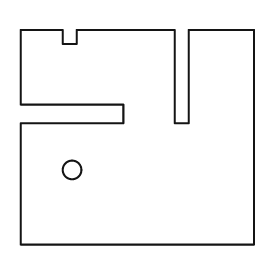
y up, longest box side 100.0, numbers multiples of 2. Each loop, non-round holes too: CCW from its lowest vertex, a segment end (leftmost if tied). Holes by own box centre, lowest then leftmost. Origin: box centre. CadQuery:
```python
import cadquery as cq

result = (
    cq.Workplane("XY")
    .moveTo(-50.0, -46.0)
    .lineTo(50.0, -46.0)
    .lineTo(50.0, 46.0)
    .lineTo(22.0, 46.0)
    .lineTo(22.0, 6.0)
    .lineTo(16.0, 6.0)
    .lineTo(16.0, 46.0)
    .lineTo(-26.0, 46.0)
    .lineTo(-26.0, 40.0)
    .lineTo(-32.0, 40.0)
    .lineTo(-32.0, 46.0)
    .lineTo(-50.0, 46.0)
    .lineTo(-50.0, 14.0)
    .lineTo(-6.0, 14.0)
    .lineTo(-6.0, 6.0)
    .lineTo(-50.0, 6.0)
    .close()
    .moveTo(-28.0, -14.0)
    .circle(4.0)
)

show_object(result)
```